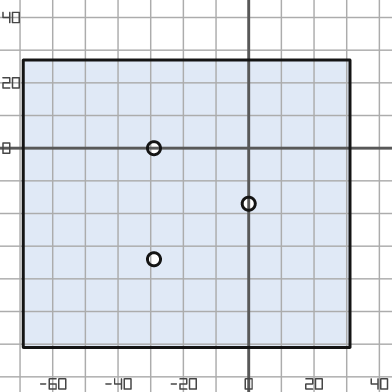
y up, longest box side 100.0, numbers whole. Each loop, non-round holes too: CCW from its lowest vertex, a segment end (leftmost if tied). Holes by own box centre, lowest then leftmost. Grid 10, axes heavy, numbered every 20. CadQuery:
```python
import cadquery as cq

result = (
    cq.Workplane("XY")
    .moveTo(-69.0, -61.0)
    .lineTo(31.0, -61.0)
    .lineTo(31.0, 27.0)
    .lineTo(-69.0, 27.0)
    .close()
    .moveTo(-29.0, -34.0)
    .circle(2.0)
    .moveTo(0.0, -17.0)
    .circle(2.0)
    .moveTo(-29.0, 0.0)
    .circle(2.0)
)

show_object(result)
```